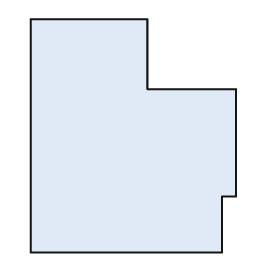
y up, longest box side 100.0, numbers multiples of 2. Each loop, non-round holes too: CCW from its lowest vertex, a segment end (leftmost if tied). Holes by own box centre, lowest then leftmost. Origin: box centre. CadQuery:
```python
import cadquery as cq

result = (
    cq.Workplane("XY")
    .moveTo(-44.0, -50.0)
    .lineTo(38.0, -50.0)
    .lineTo(38.0, -26.0)
    .lineTo(44.0, -26.0)
    .lineTo(44.0, 20.0)
    .lineTo(6.0, 20.0)
    .lineTo(6.0, 50.0)
    .lineTo(-44.0, 50.0)
    .close()
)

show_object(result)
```